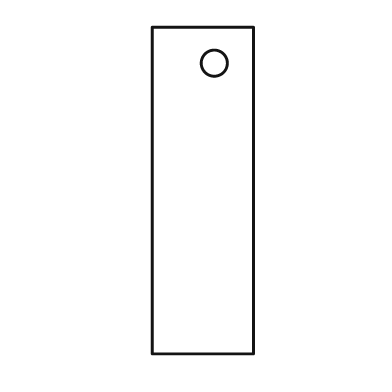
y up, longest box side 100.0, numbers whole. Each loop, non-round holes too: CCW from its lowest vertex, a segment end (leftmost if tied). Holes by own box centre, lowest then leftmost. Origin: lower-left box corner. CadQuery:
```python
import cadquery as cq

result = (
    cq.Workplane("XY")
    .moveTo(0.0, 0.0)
    .lineTo(31.0, 0.0)
    .lineTo(31.0, 100.0)
    .lineTo(0.0, 100.0)
    .close()
    .moveTo(19.0, 89.0)
    .circle(4.0)
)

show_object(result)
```